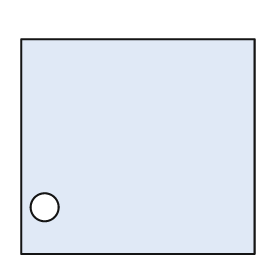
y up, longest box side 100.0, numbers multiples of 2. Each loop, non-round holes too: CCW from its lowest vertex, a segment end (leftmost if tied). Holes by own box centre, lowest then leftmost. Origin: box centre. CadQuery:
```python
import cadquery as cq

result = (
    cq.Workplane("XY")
    .moveTo(-50.0, -46.0)
    .lineTo(50.0, -46.0)
    .lineTo(50.0, 46.0)
    .lineTo(-50.0, 46.0)
    .close()
    .moveTo(-40.0, -26.0)
    .circle(6.0)
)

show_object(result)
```